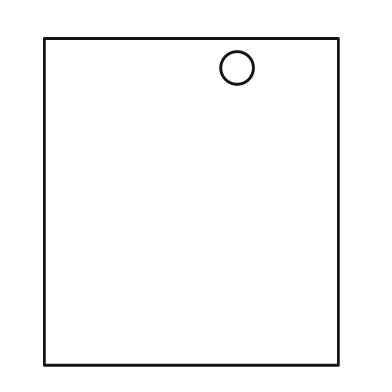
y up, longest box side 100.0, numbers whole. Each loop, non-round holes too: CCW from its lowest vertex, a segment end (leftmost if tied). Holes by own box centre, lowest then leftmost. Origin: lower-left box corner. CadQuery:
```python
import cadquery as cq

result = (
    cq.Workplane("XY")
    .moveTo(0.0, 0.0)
    .lineTo(90.0, 0.0)
    .lineTo(90.0, 100.0)
    .lineTo(0.0, 100.0)
    .close()
    .moveTo(59.0, 91.0)
    .circle(5.0)
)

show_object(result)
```